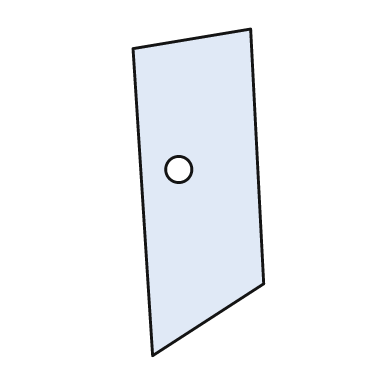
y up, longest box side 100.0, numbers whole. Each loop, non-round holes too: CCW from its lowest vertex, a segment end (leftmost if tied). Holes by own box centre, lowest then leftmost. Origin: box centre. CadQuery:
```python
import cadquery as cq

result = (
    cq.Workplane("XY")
    .moveTo(-14.0, -50.0)
    .lineTo(20.0, -28.0)
    .lineTo(16.0, 50.0)
    .lineTo(-20.0, 44.0)
    .close()
    .moveTo(-6.0, 7.0)
    .circle(4.0)
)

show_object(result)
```